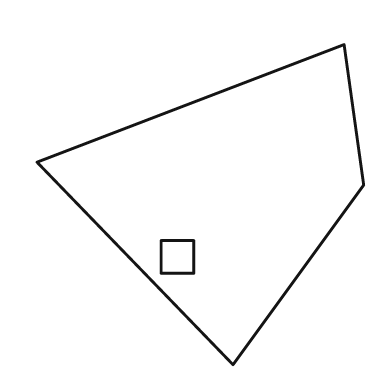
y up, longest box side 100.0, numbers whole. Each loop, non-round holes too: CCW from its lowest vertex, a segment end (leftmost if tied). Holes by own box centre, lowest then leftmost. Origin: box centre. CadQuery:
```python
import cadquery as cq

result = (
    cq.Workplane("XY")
    .moveTo(10.0, -49.0)
    .lineTo(50.0, 6.0)
    .lineTo(44.0, 49.0)
    .lineTo(-50.0, 13.0)
    .close()
    .moveTo(-12.0, -21.0)
    .lineTo(-2.0, -21.0)
    .lineTo(-2.0, -11.0)
    .lineTo(-12.0, -11.0)
    .close()
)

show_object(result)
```